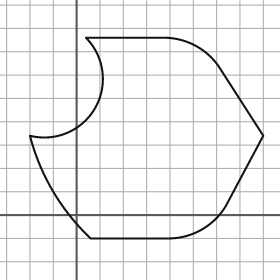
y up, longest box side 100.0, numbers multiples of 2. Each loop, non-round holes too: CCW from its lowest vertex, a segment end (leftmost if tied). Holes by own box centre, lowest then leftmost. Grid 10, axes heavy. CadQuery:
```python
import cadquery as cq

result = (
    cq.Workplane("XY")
    .moveTo(6.0, -10.0)
    .lineTo(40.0, -10.0)
    .threePointArc((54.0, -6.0), (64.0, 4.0))
    .lineTo(80.0, 34.0)
    .lineTo(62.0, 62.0)
    .threePointArc((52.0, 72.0), (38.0, 76.0))
    .lineTo(4.0, 76.0)
    .threePointArc((8.0, 46.0), (-20.0, 34.0))
    .threePointArc((-10.0, 10.0), (6.0, -10.0))
    .close()
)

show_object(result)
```